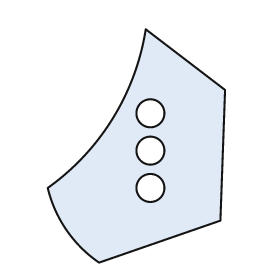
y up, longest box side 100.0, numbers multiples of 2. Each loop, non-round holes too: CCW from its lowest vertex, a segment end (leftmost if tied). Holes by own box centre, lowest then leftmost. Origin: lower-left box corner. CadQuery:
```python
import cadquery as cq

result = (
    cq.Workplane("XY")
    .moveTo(22.0, 0.0)
    .lineTo(74.0, 18.0)
    .lineTo(76.0, 74.0)
    .lineTo(42.0, 100.0)
    .threePointArc((28.0, 62.0), (0.0, 32.0))
    .threePointArc((8.0, 14.0), (22.0, 0.0))
    .close()
    .moveTo(44.0, 32.0)
    .circle(6.0)
    .moveTo(44.0, 48.0)
    .circle(6.0)
    .moveTo(44.0, 64.0)
    .circle(6.0)
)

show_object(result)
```